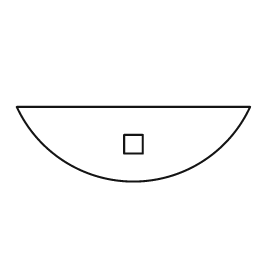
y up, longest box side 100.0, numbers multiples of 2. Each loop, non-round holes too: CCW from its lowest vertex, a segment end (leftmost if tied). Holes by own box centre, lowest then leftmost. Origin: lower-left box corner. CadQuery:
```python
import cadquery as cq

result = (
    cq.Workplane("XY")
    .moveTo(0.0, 32.0)
    .threePointArc((50.0, 0.0), (100.0, 32.0))
    .close()
    .moveTo(46.0, 12.0)
    .lineTo(54.0, 12.0)
    .lineTo(54.0, 20.0)
    .lineTo(46.0, 20.0)
    .close()
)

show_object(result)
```